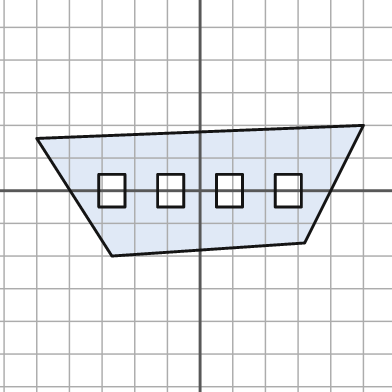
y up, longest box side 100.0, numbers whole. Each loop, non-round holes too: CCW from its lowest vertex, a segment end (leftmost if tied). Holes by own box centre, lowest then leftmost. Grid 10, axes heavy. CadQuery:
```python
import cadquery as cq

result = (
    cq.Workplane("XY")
    .moveTo(-27.0, -20.0)
    .lineTo(32.0, -16.0)
    .lineTo(50.0, 20.0)
    .lineTo(-50.0, 16.0)
    .close()
    .moveTo(-31.0, -5.0)
    .lineTo(-23.0, -5.0)
    .lineTo(-23.0, 5.0)
    .lineTo(-31.0, 5.0)
    .close()
    .moveTo(-13.0, -5.0)
    .lineTo(-5.0, -5.0)
    .lineTo(-5.0, 5.0)
    .lineTo(-13.0, 5.0)
    .close()
    .moveTo(5.0, -5.0)
    .lineTo(13.0, -5.0)
    .lineTo(13.0, 5.0)
    .lineTo(5.0, 5.0)
    .close()
    .moveTo(23.0, -5.0)
    .lineTo(31.0, -5.0)
    .lineTo(31.0, 5.0)
    .lineTo(23.0, 5.0)
    .close()
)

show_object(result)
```